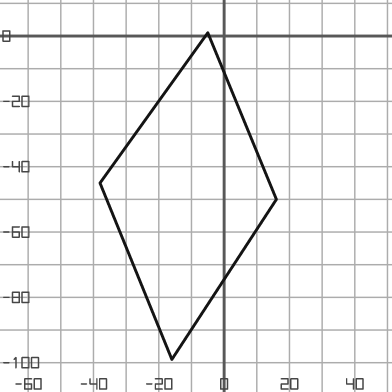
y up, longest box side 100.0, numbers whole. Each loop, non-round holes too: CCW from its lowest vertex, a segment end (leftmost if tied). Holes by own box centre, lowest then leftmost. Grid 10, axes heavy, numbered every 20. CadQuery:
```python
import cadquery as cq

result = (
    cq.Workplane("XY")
    .moveTo(-16.0, -99.0)
    .lineTo(16.0, -50.0)
    .lineTo(-5.0, 1.0)
    .lineTo(-38.0, -45.0)
    .close()
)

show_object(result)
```